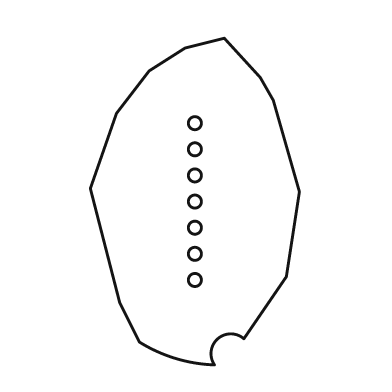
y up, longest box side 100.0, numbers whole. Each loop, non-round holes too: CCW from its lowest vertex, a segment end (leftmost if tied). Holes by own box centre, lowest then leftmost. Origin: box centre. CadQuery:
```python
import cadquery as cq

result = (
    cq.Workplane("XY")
    .moveTo(6.0, -50.0)
    .threePointArc((7.0, -42.0), (15.0, -42.0))
    .lineTo(28.0, -23.0)
    .lineTo(32.0, 3.0)
    .lineTo(24.0, 31.0)
    .lineTo(20.0, 38.0)
    .lineTo(9.0, 50.0)
    .lineTo(-3.0, 47.0)
    .lineTo(-14.0, 40.0)
    .lineTo(-24.0, 27.0)
    .lineTo(-32.0, 4.0)
    .lineTo(-23.0, -31.0)
    .lineTo(-17.0, -43.0)
    .threePointArc((-6.0, -48.0), (6.0, -50.0))
    .close()
    .moveTo(0.0, -24.0)
    .circle(2.0)
    .moveTo(0.0, -16.0)
    .circle(2.0)
    .moveTo(0.0, -8.0)
    .circle(2.0)
    .moveTo(0.0, 0.0)
    .circle(2.0)
    .moveTo(0.0, 8.0)
    .circle(2.0)
    .moveTo(0.0, 16.0)
    .circle(2.0)
    .moveTo(0.0, 24.0)
    .circle(2.0)
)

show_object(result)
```